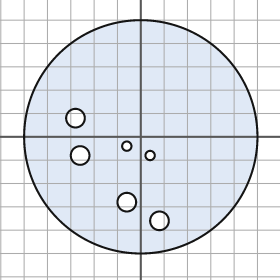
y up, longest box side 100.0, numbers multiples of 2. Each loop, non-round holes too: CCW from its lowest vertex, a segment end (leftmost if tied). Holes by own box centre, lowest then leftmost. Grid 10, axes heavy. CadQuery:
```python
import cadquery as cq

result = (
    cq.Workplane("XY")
    .moveTo(0.0, 0.0)
    .circle(50.0)
    .moveTo(8.0, -36.0)
    .circle(4.0)
    .moveTo(-6.0, -28.0)
    .circle(4.0)
    .moveTo(-26.0, -8.0)
    .circle(4.0)
    .moveTo(4.0, -8.0)
    .circle(2.0)
    .moveTo(-6.0, -4.0)
    .circle(2.0)
    .moveTo(-28.0, 8.0)
    .circle(4.0)
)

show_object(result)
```